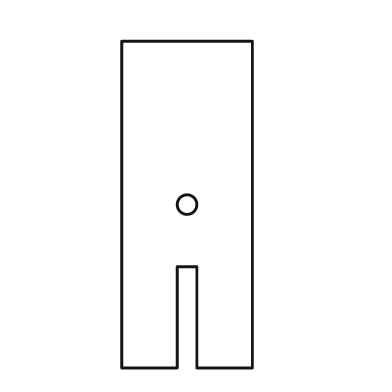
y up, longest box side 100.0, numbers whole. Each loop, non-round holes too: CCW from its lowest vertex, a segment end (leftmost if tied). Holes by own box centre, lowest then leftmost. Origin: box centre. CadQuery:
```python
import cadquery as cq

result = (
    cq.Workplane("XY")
    .moveTo(-20.0, -50.0)
    .lineTo(-3.0, -50.0)
    .lineTo(-3.0, -19.0)
    .lineTo(3.0, -19.0)
    .lineTo(3.0, -50.0)
    .lineTo(20.0, -50.0)
    .lineTo(20.0, 50.0)
    .lineTo(-20.0, 50.0)
    .close()
    .moveTo(0.0, 0.0)
    .circle(3.0)
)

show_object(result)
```